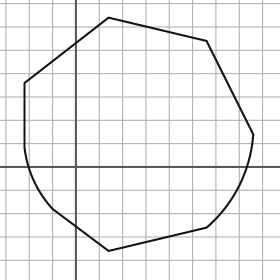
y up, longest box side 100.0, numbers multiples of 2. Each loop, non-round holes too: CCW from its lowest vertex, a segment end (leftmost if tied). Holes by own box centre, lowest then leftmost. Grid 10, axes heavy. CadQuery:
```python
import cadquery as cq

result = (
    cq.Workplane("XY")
    .moveTo(14.0, -36.0)
    .lineTo(56.0, -26.0)
    .threePointArc((70.0, -8.0), (76.0, 14.0))
    .lineTo(56.0, 54.0)
    .lineTo(14.0, 64.0)
    .lineTo(-22.0, 36.0)
    .lineTo(-22.0, 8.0)
    .threePointArc((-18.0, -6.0), (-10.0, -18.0))
    .close()
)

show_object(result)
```